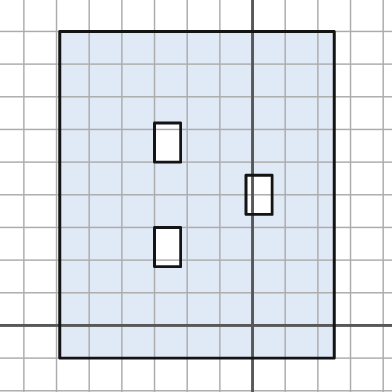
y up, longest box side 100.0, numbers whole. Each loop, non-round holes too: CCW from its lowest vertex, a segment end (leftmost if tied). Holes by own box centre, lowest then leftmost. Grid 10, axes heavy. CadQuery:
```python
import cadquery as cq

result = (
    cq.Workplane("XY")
    .moveTo(-59.0, -10.0)
    .lineTo(25.0, -10.0)
    .lineTo(25.0, 90.0)
    .lineTo(-59.0, 90.0)
    .close()
    .moveTo(-30.0, 18.0)
    .lineTo(-22.0, 18.0)
    .lineTo(-22.0, 30.0)
    .lineTo(-30.0, 30.0)
    .close()
    .moveTo(-2.0, 34.0)
    .lineTo(6.0, 34.0)
    .lineTo(6.0, 46.0)
    .lineTo(-2.0, 46.0)
    .close()
    .moveTo(-30.0, 50.0)
    .lineTo(-22.0, 50.0)
    .lineTo(-22.0, 62.0)
    .lineTo(-30.0, 62.0)
    .close()
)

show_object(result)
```